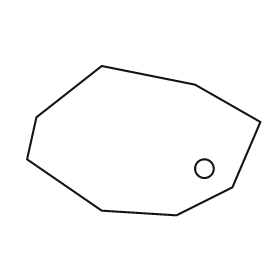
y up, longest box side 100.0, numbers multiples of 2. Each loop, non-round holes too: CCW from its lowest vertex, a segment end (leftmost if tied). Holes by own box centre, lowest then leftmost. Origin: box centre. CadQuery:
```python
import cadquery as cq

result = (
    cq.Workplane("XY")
    .moveTo(14.0, -32.0)
    .lineTo(38.0, -20.0)
    .lineTo(50.0, 8.0)
    .lineTo(22.0, 24.0)
    .lineTo(-18.0, 32.0)
    .lineTo(-46.0, 10.0)
    .lineTo(-50.0, -8.0)
    .lineTo(-18.0, -30.0)
    .close()
    .moveTo(26.0, -12.0)
    .circle(4.0)
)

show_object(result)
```